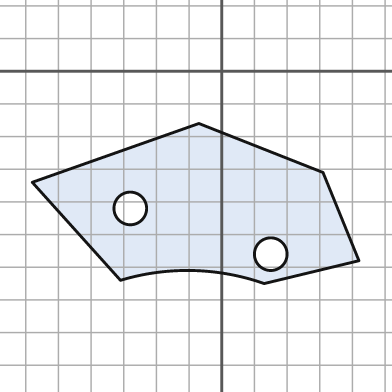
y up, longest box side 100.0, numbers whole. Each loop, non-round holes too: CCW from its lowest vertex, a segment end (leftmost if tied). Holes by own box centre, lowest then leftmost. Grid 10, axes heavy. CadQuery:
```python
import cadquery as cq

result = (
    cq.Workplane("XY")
    .moveTo(13.0, -65.0)
    .lineTo(42.0, -58.0)
    .lineTo(31.0, -31.0)
    .lineTo(-7.0, -16.0)
    .lineTo(-58.0, -34.0)
    .lineTo(-31.0, -64.0)
    .threePointArc((-9.0, -61.0), (13.0, -65.0))
    .close()
    .moveTo(15.0, -56.0)
    .circle(5.0)
    .moveTo(-28.0, -42.0)
    .circle(5.0)
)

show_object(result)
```